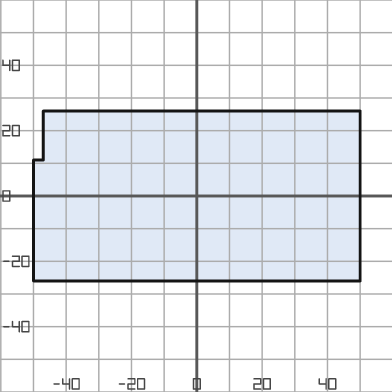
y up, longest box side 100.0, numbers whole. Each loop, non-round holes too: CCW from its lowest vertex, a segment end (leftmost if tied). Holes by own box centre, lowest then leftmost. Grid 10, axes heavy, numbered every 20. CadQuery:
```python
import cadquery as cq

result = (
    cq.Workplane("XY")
    .moveTo(-50.0, -26.0)
    .lineTo(50.0, -26.0)
    .lineTo(50.0, 26.0)
    .lineTo(-47.0, 26.0)
    .lineTo(-47.0, 11.0)
    .lineTo(-50.0, 11.0)
    .close()
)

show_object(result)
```